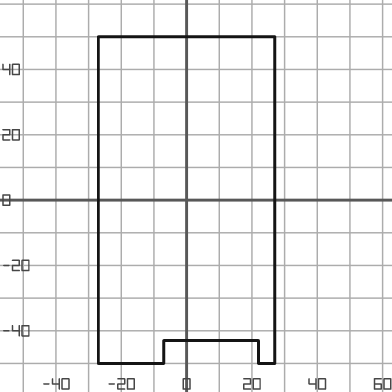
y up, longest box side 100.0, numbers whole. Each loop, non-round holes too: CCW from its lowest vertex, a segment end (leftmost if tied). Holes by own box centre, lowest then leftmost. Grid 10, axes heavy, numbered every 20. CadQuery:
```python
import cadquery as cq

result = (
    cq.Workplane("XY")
    .moveTo(-27.0, -50.0)
    .lineTo(-7.0, -50.0)
    .lineTo(-7.0, -43.0)
    .lineTo(22.0, -43.0)
    .lineTo(22.0, -50.0)
    .lineTo(27.0, -50.0)
    .lineTo(27.0, 50.0)
    .lineTo(-27.0, 50.0)
    .close()
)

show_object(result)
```